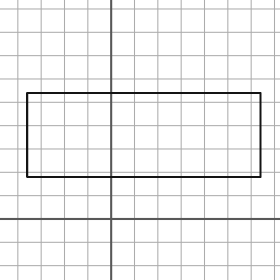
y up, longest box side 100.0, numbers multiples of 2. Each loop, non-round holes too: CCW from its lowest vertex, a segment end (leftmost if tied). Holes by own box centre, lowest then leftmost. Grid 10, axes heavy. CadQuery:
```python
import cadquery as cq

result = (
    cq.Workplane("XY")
    .moveTo(-36.0, 18.0)
    .lineTo(64.0, 18.0)
    .lineTo(64.0, 54.0)
    .lineTo(-36.0, 54.0)
    .close()
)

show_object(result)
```